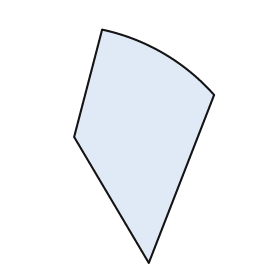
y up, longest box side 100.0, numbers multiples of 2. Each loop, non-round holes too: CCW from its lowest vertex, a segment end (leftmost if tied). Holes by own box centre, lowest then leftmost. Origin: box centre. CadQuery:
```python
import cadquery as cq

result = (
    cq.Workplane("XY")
    .moveTo(2.0, -50.0)
    .lineTo(30.0, 22.0)
    .threePointArc((8.0, 40.0), (-18.0, 50.0))
    .lineTo(-30.0, 4.0)
    .close()
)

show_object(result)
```